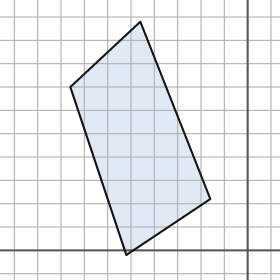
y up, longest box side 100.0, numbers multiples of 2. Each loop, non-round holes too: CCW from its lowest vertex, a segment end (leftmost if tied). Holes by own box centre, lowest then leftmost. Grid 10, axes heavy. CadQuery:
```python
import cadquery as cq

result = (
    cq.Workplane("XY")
    .moveTo(-52.0, -2.0)
    .lineTo(-16.0, 22.0)
    .lineTo(-46.0, 98.0)
    .lineTo(-76.0, 70.0)
    .close()
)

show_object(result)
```